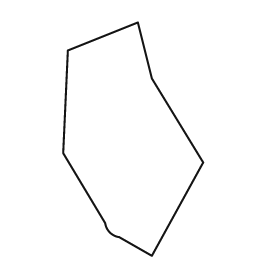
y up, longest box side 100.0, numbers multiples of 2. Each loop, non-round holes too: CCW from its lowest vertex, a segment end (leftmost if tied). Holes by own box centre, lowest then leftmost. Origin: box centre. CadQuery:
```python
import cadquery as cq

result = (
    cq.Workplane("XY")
    .moveTo(8.0, -50.0)
    .lineTo(30.0, -10.0)
    .lineTo(8.0, 26.0)
    .lineTo(2.0, 50.0)
    .lineTo(-28.0, 38.0)
    .lineTo(-30.0, -6.0)
    .lineTo(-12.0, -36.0)
    .threePointArc((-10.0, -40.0), (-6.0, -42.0))
    .close()
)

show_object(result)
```